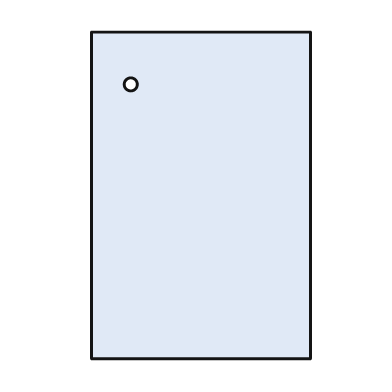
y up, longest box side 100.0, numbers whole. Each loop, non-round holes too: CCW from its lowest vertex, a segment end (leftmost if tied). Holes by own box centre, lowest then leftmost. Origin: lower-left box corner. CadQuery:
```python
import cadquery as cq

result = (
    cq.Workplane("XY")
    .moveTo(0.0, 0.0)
    .lineTo(67.0, 0.0)
    .lineTo(67.0, 100.0)
    .lineTo(0.0, 100.0)
    .close()
    .moveTo(12.0, 84.0)
    .circle(2.0)
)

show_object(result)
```